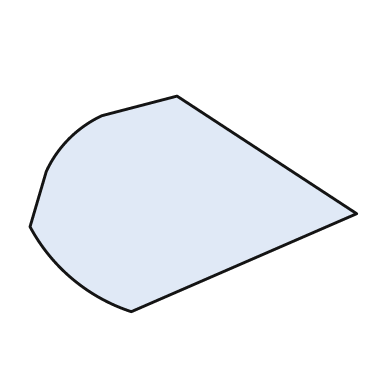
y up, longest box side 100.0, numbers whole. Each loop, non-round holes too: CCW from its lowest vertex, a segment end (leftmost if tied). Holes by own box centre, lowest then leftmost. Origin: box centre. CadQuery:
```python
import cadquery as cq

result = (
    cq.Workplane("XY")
    .moveTo(-19.0, -33.0)
    .lineTo(50.0, -3.0)
    .lineTo(-5.0, 33.0)
    .lineTo(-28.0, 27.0)
    .threePointArc((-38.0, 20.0), (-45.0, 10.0))
    .lineTo(-50.0, -7.0)
    .threePointArc((-37.0, -23.0), (-19.0, -33.0))
    .close()
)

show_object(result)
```